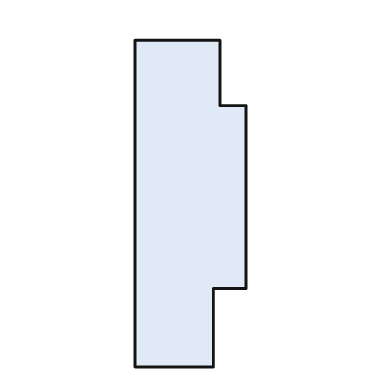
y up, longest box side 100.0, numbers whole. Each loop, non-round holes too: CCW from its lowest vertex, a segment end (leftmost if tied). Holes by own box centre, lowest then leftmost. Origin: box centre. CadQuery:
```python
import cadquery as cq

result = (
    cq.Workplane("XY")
    .moveTo(-17.0, -50.0)
    .lineTo(7.0, -50.0)
    .lineTo(7.0, -26.0)
    .lineTo(17.0, -26.0)
    .lineTo(17.0, 30.0)
    .lineTo(9.0, 30.0)
    .lineTo(9.0, 50.0)
    .lineTo(-17.0, 50.0)
    .close()
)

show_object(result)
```